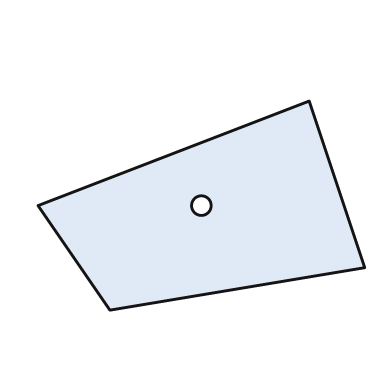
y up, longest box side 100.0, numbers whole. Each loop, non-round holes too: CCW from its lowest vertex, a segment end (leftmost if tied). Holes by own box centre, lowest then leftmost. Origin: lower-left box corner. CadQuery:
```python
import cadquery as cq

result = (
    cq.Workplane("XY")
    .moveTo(22.0, 0.0)
    .lineTo(100.0, 13.0)
    .lineTo(83.0, 64.0)
    .lineTo(0.0, 32.0)
    .close()
    .moveTo(50.0, 32.0)
    .circle(3.0)
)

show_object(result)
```